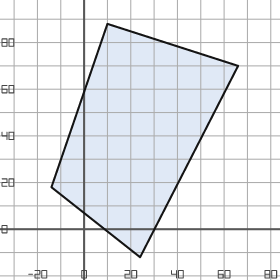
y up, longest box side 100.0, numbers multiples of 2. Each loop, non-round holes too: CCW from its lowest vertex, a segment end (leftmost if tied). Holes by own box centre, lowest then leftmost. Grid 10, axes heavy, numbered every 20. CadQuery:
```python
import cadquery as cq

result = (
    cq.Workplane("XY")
    .moveTo(24.0, -12.0)
    .lineTo(66.0, 70.0)
    .lineTo(10.0, 88.0)
    .lineTo(-14.0, 18.0)
    .close()
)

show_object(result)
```